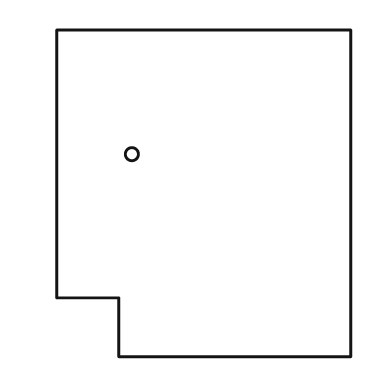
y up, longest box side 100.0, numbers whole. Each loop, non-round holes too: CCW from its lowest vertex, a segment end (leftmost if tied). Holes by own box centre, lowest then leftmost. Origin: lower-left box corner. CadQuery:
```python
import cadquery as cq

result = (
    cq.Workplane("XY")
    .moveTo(19.0, 0.0)
    .lineTo(90.0, 0.0)
    .lineTo(90.0, 100.0)
    .lineTo(0.0, 100.0)
    .lineTo(0.0, 18.0)
    .lineTo(19.0, 18.0)
    .close()
    .moveTo(23.0, 62.0)
    .circle(2.0)
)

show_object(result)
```